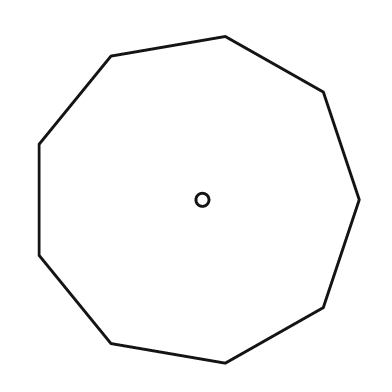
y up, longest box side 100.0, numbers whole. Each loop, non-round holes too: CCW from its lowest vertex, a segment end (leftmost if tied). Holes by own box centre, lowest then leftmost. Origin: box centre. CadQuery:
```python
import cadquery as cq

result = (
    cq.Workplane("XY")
    .moveTo(8.0, -50.0)
    .lineTo(38.0, -33.0)
    .lineTo(49.0, 0.0)
    .lineTo(38.0, 33.0)
    .lineTo(8.0, 50.0)
    .lineTo(-27.0, 44.0)
    .lineTo(-49.0, 17.0)
    .lineTo(-49.0, -17.0)
    .lineTo(-27.0, -44.0)
    .close()
    .moveTo(1.0, 0.0)
    .circle(2.0)
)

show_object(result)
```